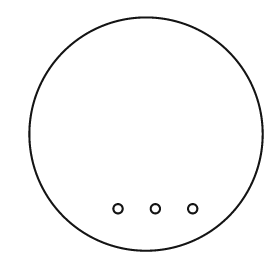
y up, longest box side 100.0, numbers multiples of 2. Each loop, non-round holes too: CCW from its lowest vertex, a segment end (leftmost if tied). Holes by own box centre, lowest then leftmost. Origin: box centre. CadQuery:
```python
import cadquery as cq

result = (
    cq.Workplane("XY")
    .moveTo(0.0, 0.0)
    .circle(50.0)
    .moveTo(-12.0, -32.0)
    .circle(2.0)
    .moveTo(4.0, -32.0)
    .circle(2.0)
    .moveTo(20.0, -32.0)
    .circle(2.0)
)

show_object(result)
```